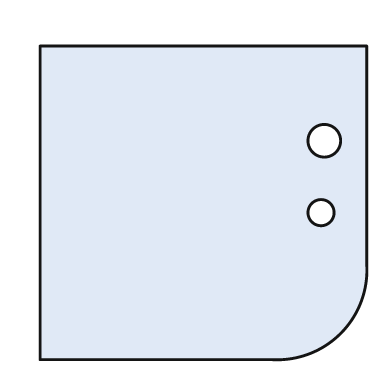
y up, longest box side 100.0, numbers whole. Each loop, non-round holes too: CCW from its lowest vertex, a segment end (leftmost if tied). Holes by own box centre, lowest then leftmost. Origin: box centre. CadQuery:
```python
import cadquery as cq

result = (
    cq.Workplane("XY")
    .moveTo(-50.0, -48.0)
    .lineTo(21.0, -48.0)
    .threePointArc((42.0, -40.0), (50.0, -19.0))
    .lineTo(50.0, 48.0)
    .lineTo(-50.0, 48.0)
    .close()
    .moveTo(36.0, -3.0)
    .circle(4.0)
    .moveTo(37.0, 19.0)
    .circle(5.0)
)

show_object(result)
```